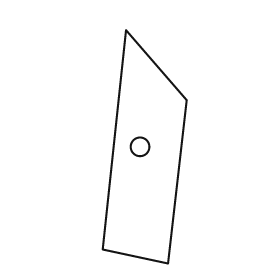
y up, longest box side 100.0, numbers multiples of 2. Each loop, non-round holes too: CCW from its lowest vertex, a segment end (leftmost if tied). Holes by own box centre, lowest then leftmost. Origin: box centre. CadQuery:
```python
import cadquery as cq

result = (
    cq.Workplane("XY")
    .moveTo(10.0, -50.0)
    .lineTo(18.0, 20.0)
    .lineTo(-8.0, 50.0)
    .lineTo(-18.0, -44.0)
    .close()
    .moveTo(-2.0, 0.0)
    .circle(4.0)
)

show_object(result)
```